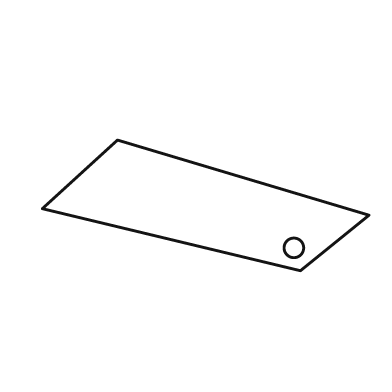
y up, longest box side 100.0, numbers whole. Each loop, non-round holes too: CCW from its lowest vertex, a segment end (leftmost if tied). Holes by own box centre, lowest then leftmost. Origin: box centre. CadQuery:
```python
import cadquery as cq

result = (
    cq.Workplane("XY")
    .moveTo(29.0, -20.0)
    .lineTo(50.0, -3.0)
    .lineTo(-27.0, 20.0)
    .lineTo(-50.0, -1.0)
    .close()
    .moveTo(27.0, -13.0)
    .circle(3.0)
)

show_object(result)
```